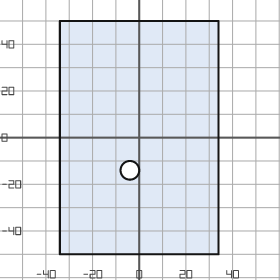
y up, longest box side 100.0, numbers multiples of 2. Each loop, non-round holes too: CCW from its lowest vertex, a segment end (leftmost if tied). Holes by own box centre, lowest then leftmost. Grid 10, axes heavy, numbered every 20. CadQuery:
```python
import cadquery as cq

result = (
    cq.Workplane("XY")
    .moveTo(-34.0, -50.0)
    .lineTo(34.0, -50.0)
    .lineTo(34.0, 50.0)
    .lineTo(-34.0, 50.0)
    .close()
    .moveTo(-4.0, -14.0)
    .circle(4.0)
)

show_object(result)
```